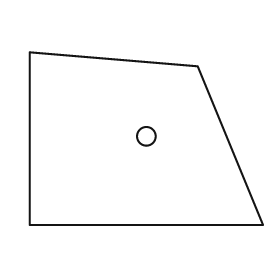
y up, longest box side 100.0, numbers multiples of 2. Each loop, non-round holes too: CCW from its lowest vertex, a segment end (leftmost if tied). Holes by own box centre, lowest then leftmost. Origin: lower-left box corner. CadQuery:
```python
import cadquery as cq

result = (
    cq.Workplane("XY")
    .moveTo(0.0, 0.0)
    .lineTo(100.0, 0.0)
    .lineTo(72.0, 68.0)
    .lineTo(0.0, 74.0)
    .close()
    .moveTo(50.0, 38.0)
    .circle(4.0)
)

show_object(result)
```